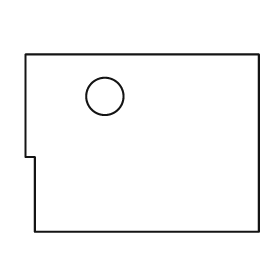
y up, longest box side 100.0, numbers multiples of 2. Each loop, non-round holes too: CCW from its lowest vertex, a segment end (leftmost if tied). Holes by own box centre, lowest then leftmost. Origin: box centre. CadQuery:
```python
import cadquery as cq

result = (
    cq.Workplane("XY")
    .moveTo(-46.0, -38.0)
    .lineTo(50.0, -38.0)
    .lineTo(50.0, 38.0)
    .lineTo(-50.0, 38.0)
    .lineTo(-50.0, -6.0)
    .lineTo(-46.0, -6.0)
    .close()
    .moveTo(-16.0, 20.0)
    .circle(8.0)
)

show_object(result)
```